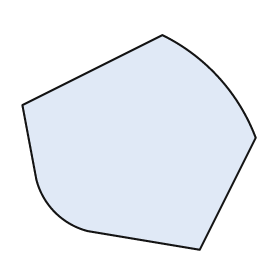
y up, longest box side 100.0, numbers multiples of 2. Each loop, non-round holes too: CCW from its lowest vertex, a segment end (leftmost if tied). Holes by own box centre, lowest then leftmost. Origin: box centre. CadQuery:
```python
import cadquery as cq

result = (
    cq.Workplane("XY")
    .moveTo(26.0, -46.0)
    .lineTo(50.0, 2.0)
    .threePointArc((34.0, 28.0), (10.0, 46.0))
    .lineTo(-50.0, 16.0)
    .lineTo(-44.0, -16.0)
    .threePointArc((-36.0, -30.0), (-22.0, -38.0))
    .close()
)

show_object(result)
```